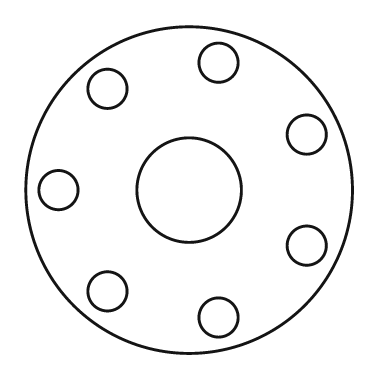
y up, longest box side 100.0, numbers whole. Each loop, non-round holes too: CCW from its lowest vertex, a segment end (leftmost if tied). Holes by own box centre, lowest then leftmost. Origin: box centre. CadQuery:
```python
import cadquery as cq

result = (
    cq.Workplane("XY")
    .moveTo(0.0, 0.0)
    .circle(50.0)
    .moveTo(9.0, -39.0)
    .circle(6.0)
    .moveTo(-25.0, -31.0)
    .circle(6.0)
    .moveTo(36.0, -17.0)
    .circle(6.0)
    .moveTo(-40.0, 0.0)
    .circle(6.0)
    .moveTo(0.0, 0.0)
    .circle(16.0)
    .moveTo(36.0, 17.0)
    .circle(6.0)
    .moveTo(-25.0, 31.0)
    .circle(6.0)
    .moveTo(9.0, 39.0)
    .circle(6.0)
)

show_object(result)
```